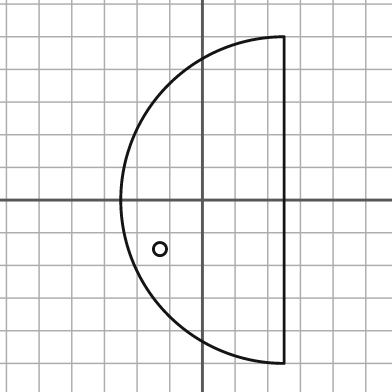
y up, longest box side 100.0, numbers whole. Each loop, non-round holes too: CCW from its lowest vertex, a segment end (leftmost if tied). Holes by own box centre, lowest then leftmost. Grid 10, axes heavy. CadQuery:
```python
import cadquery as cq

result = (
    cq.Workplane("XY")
    .moveTo(25.0, -50.0)
    .lineTo(25.0, 50.0)
    .threePointArc((-25.0, 0.0), (25.0, -50.0))
    .close()
    .moveTo(-13.0, -15.0)
    .circle(2.0)
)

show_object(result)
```